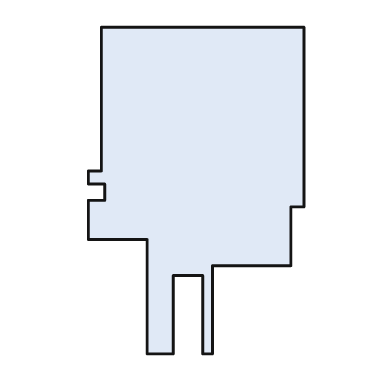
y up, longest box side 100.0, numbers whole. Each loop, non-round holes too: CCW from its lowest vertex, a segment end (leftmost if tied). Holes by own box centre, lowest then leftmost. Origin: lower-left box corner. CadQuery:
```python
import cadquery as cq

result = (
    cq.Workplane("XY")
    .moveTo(18.0, 0.0)
    .lineTo(26.0, 0.0)
    .lineTo(26.0, 24.0)
    .lineTo(35.0, 24.0)
    .lineTo(35.0, 0.0)
    .lineTo(38.0, 0.0)
    .lineTo(38.0, 27.0)
    .lineTo(62.0, 27.0)
    .lineTo(62.0, 45.0)
    .lineTo(66.0, 45.0)
    .lineTo(66.0, 100.0)
    .lineTo(4.0, 100.0)
    .lineTo(4.0, 56.0)
    .lineTo(0.0, 56.0)
    .lineTo(0.0, 52.0)
    .lineTo(5.0, 52.0)
    .lineTo(5.0, 47.0)
    .lineTo(0.0, 47.0)
    .lineTo(0.0, 35.0)
    .lineTo(18.0, 35.0)
    .close()
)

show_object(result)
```